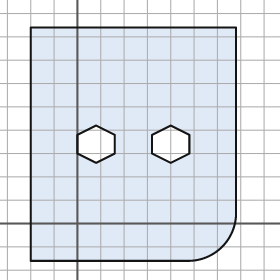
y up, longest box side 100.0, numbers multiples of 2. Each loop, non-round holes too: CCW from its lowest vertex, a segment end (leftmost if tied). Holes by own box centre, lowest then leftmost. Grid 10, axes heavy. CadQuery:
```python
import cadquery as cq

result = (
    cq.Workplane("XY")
    .moveTo(-20.0, -16.0)
    .lineTo(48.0, -16.0)
    .threePointArc((62.0, -10.0), (68.0, 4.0))
    .lineTo(68.0, 84.0)
    .lineTo(-20.0, 84.0)
    .close()
    .moveTo(8.0, 26.0)
    .lineTo(16.0, 30.0)
    .lineTo(16.0, 38.0)
    .lineTo(8.0, 42.0)
    .lineTo(0.0, 38.0)
    .lineTo(0.0, 30.0)
    .close()
    .moveTo(40.0, 26.0)
    .lineTo(48.0, 30.0)
    .lineTo(48.0, 38.0)
    .lineTo(40.0, 42.0)
    .lineTo(32.0, 38.0)
    .lineTo(32.0, 30.0)
    .close()
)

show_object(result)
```